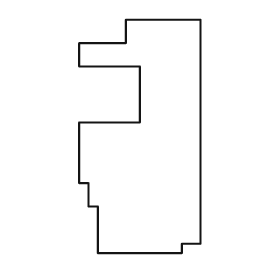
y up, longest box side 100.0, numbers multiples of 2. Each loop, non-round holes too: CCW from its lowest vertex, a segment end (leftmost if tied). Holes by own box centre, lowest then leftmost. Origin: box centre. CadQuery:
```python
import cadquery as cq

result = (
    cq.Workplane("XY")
    .moveTo(-18.0, -50.0)
    .lineTo(18.0, -50.0)
    .lineTo(18.0, -46.0)
    .lineTo(26.0, -46.0)
    .lineTo(26.0, 50.0)
    .lineTo(-6.0, 50.0)
    .lineTo(-6.0, 40.0)
    .lineTo(-26.0, 40.0)
    .lineTo(-26.0, 30.0)
    .lineTo(0.0, 30.0)
    .lineTo(0.0, 6.0)
    .lineTo(-26.0, 6.0)
    .lineTo(-26.0, -20.0)
    .lineTo(-22.0, -20.0)
    .lineTo(-22.0, -30.0)
    .lineTo(-18.0, -30.0)
    .close()
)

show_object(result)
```